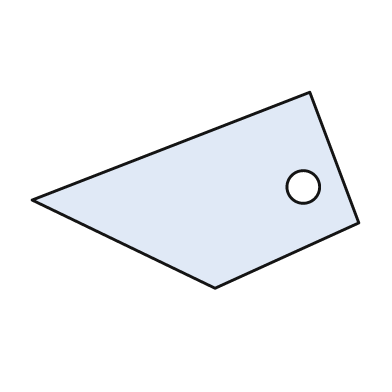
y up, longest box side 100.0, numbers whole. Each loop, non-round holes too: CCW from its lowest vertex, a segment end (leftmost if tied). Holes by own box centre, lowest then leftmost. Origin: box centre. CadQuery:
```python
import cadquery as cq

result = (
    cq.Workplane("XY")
    .moveTo(6.0, -30.0)
    .lineTo(50.0, -10.0)
    .lineTo(35.0, 30.0)
    .lineTo(-50.0, -3.0)
    .close()
    .moveTo(33.0, 1.0)
    .circle(5.0)
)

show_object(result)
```